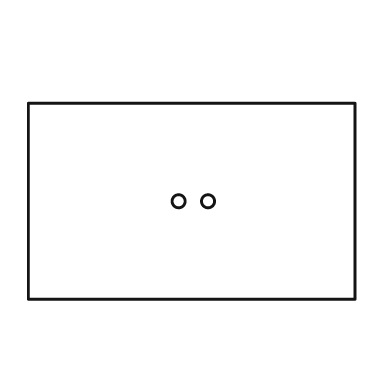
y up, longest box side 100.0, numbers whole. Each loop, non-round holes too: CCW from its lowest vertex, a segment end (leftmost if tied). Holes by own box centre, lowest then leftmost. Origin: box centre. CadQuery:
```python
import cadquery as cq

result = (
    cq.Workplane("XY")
    .moveTo(-50.0, -30.0)
    .lineTo(50.0, -30.0)
    .lineTo(50.0, 30.0)
    .lineTo(-50.0, 30.0)
    .close()
    .moveTo(-4.0, 0.0)
    .circle(2.0)
    .moveTo(5.0, 0.0)
    .circle(2.0)
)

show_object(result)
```